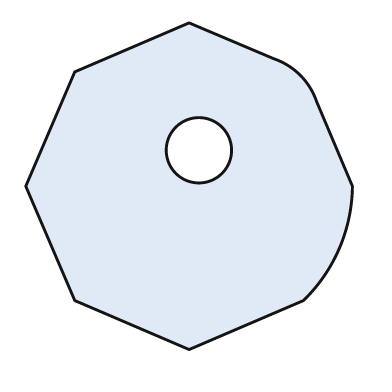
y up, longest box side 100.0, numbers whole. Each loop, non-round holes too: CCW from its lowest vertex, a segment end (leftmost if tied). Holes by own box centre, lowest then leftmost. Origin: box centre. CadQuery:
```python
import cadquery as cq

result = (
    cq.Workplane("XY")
    .moveTo(0.0, -50.0)
    .lineTo(35.0, -35.0)
    .threePointArc((46.0, -19.0), (50.0, 0.0))
    .lineTo(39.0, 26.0)
    .threePointArc((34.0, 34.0), (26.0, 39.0))
    .lineTo(0.0, 50.0)
    .lineTo(-35.0, 35.0)
    .lineTo(-50.0, 0.0)
    .lineTo(-35.0, -35.0)
    .close()
    .moveTo(3.0, 11.0)
    .circle(10.0)
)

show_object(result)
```